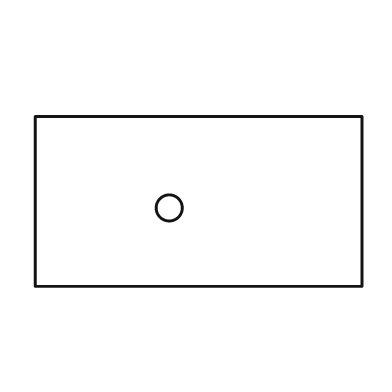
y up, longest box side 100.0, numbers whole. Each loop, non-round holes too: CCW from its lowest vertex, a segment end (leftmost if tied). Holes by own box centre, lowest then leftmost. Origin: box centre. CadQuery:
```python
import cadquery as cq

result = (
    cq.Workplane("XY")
    .moveTo(-50.0, -26.0)
    .lineTo(50.0, -26.0)
    .lineTo(50.0, 26.0)
    .lineTo(-50.0, 26.0)
    .close()
    .moveTo(-9.0, -2.0)
    .circle(4.0)
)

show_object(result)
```